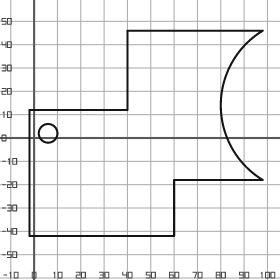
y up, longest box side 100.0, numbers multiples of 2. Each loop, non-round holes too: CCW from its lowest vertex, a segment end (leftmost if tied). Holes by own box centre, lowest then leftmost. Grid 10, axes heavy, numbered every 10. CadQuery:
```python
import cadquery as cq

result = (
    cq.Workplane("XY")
    .moveTo(-2.0, -42.0)
    .lineTo(60.0, -42.0)
    .lineTo(60.0, -18.0)
    .lineTo(98.0, -18.0)
    .threePointArc((80.0, 14.0), (98.0, 46.0))
    .lineTo(40.0, 46.0)
    .lineTo(40.0, 12.0)
    .lineTo(-2.0, 12.0)
    .close()
    .moveTo(6.0, 2.0)
    .circle(4.0)
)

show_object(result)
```